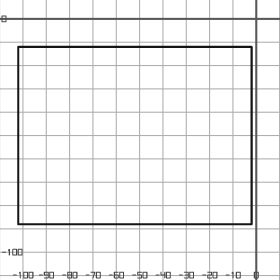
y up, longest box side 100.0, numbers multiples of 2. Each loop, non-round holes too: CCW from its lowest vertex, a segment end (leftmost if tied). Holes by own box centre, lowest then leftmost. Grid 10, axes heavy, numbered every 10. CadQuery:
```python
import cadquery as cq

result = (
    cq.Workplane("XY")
    .moveTo(-102.0, -88.0)
    .lineTo(-2.0, -88.0)
    .lineTo(-2.0, -12.0)
    .lineTo(-102.0, -12.0)
    .close()
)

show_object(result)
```